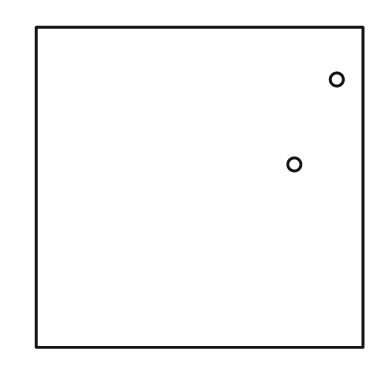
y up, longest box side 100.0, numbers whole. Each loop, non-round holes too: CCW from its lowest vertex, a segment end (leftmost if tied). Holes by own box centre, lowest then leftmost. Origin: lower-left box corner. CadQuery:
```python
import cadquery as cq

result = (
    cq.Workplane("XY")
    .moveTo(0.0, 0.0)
    .lineTo(100.0, 0.0)
    .lineTo(100.0, 98.0)
    .lineTo(0.0, 98.0)
    .close()
    .moveTo(79.0, 56.0)
    .circle(2.0)
    .moveTo(92.0, 82.0)
    .circle(2.0)
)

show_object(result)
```